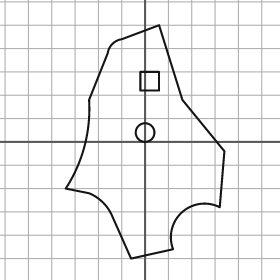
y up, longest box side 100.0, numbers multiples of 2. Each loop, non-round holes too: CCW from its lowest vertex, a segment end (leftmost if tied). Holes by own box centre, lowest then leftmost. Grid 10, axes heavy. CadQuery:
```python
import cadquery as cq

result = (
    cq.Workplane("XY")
    .moveTo(-6.0, -50.0)
    .lineTo(12.0, -46.0)
    .threePointArc((16.0, -30.0), (32.0, -28.0))
    .lineTo(34.0, -4.0)
    .lineTo(16.0, 18.0)
    .lineTo(6.0, 50.0)
    .lineTo(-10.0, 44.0)
    .threePointArc((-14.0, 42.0), (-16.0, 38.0))
    .lineTo(-24.0, 18.0)
    .threePointArc((-26.0, -2.0), (-34.0, -20.0))
    .lineTo(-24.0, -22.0)
    .threePointArc((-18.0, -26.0), (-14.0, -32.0))
    .close()
    .moveTo(0.0, 4.0)
    .circle(4.0)
    .moveTo(-2.0, 22.0)
    .lineTo(6.0, 22.0)
    .lineTo(6.0, 30.0)
    .lineTo(-2.0, 30.0)
    .close()
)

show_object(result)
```